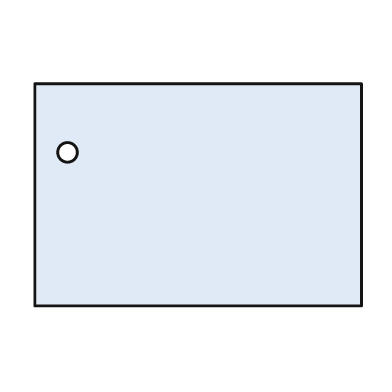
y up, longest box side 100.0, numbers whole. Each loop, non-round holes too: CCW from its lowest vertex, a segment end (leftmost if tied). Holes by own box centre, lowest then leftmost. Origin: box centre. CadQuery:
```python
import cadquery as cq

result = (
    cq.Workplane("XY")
    .moveTo(-50.0, -34.0)
    .lineTo(50.0, -34.0)
    .lineTo(50.0, 34.0)
    .lineTo(-50.0, 34.0)
    .close()
    .moveTo(-40.0, 13.0)
    .circle(3.0)
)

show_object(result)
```